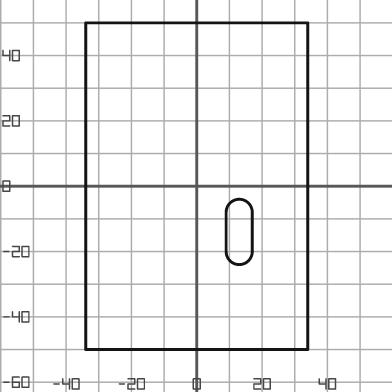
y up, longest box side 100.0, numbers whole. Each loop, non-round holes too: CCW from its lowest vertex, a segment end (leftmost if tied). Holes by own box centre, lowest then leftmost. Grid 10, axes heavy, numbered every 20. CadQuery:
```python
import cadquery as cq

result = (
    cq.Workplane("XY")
    .moveTo(-34.0, -50.0)
    .lineTo(34.0, -50.0)
    .lineTo(34.0, 50.0)
    .lineTo(-34.0, 50.0)
    .close()
    .moveTo(9.0, -20.0)
    .threePointArc((13.0, -24.0), (17.0, -20.0))
    .lineTo(17.0, -8.0)
    .threePointArc((13.0, -4.0), (9.0, -8.0))
    .close()
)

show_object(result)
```